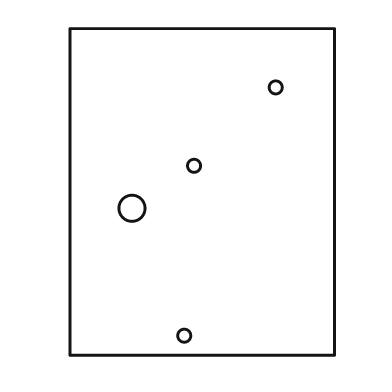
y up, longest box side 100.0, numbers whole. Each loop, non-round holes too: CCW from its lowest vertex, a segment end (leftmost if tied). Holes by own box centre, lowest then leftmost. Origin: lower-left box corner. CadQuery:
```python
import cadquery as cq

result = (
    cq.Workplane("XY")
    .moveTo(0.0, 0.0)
    .lineTo(81.0, 0.0)
    .lineTo(81.0, 100.0)
    .lineTo(0.0, 100.0)
    .close()
    .moveTo(35.0, 6.0)
    .circle(2.0)
    .moveTo(19.0, 45.0)
    .circle(4.0)
    .moveTo(38.0, 58.0)
    .circle(2.0)
    .moveTo(63.0, 82.0)
    .circle(2.0)
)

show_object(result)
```